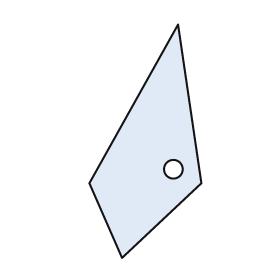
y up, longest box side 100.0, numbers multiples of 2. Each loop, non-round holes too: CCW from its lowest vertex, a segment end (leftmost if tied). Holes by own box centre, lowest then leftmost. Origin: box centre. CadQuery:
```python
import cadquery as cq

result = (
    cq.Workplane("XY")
    .moveTo(-10.0, -50.0)
    .lineTo(24.0, -18.0)
    .lineTo(14.0, 50.0)
    .lineTo(-24.0, -18.0)
    .close()
    .moveTo(12.0, -12.0)
    .circle(4.0)
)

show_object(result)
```